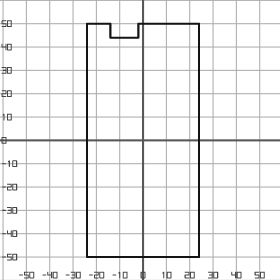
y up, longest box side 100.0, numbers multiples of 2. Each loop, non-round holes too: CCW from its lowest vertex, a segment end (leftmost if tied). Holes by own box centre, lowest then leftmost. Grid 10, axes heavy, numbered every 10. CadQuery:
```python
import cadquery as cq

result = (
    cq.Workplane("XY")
    .moveTo(-24.0, -50.0)
    .lineTo(24.0, -50.0)
    .lineTo(24.0, 50.0)
    .lineTo(-2.0, 50.0)
    .lineTo(-2.0, 44.0)
    .lineTo(-14.0, 44.0)
    .lineTo(-14.0, 50.0)
    .lineTo(-24.0, 50.0)
    .close()
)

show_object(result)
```